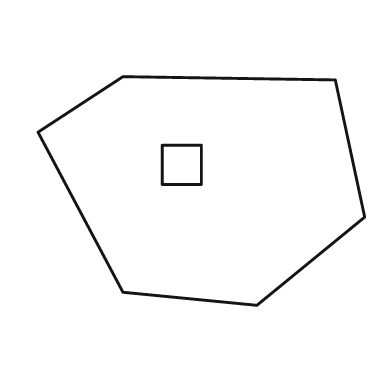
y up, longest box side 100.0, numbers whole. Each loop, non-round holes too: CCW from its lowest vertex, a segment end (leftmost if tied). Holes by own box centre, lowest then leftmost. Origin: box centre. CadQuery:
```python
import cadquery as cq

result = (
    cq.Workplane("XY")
    .moveTo(17.0, -35.0)
    .lineTo(50.0, -8.0)
    .lineTo(41.0, 34.0)
    .lineTo(-24.0, 35.0)
    .lineTo(-50.0, 18.0)
    .lineTo(-24.0, -31.0)
    .close()
    .moveTo(-12.0, 2.0)
    .lineTo(0.0, 2.0)
    .lineTo(0.0, 14.0)
    .lineTo(-12.0, 14.0)
    .close()
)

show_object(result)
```